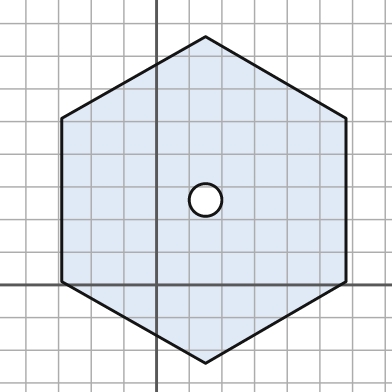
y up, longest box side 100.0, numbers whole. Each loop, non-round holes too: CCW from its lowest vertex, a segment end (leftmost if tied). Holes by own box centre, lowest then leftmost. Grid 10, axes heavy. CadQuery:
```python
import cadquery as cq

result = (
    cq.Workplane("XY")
    .moveTo(15.0, -24.0)
    .lineTo(58.0, 1.0)
    .lineTo(58.0, 51.0)
    .lineTo(15.0, 76.0)
    .lineTo(-29.0, 51.0)
    .lineTo(-29.0, 1.0)
    .close()
    .moveTo(15.0, 26.0)
    .circle(5.0)
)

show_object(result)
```